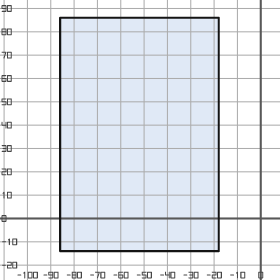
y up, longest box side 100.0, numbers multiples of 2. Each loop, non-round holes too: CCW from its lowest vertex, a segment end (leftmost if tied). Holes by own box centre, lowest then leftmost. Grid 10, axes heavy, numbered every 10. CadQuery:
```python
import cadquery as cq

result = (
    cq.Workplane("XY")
    .moveTo(-86.0, -14.0)
    .lineTo(-18.0, -14.0)
    .lineTo(-18.0, 86.0)
    .lineTo(-86.0, 86.0)
    .close()
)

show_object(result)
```